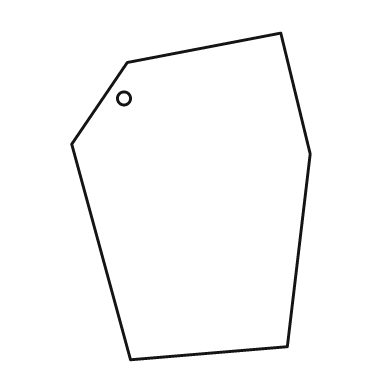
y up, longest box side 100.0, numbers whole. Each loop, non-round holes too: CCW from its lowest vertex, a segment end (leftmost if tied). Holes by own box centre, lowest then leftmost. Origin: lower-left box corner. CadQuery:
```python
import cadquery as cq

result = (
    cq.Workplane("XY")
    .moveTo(18.0, 0.0)
    .lineTo(66.0, 4.0)
    .lineTo(73.0, 63.0)
    .lineTo(64.0, 100.0)
    .lineTo(17.0, 91.0)
    .lineTo(0.0, 66.0)
    .close()
    .moveTo(16.0, 80.0)
    .circle(2.0)
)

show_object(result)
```